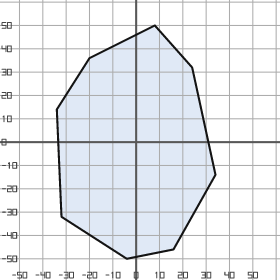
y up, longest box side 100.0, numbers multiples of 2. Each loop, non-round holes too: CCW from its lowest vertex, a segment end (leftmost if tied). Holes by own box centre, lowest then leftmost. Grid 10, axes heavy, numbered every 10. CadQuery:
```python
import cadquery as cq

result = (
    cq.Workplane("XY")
    .moveTo(-4.0, -50.0)
    .lineTo(16.0, -46.0)
    .lineTo(34.0, -14.0)
    .lineTo(24.0, 32.0)
    .lineTo(8.0, 50.0)
    .lineTo(-20.0, 36.0)
    .lineTo(-34.0, 14.0)
    .lineTo(-32.0, -32.0)
    .close()
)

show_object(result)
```